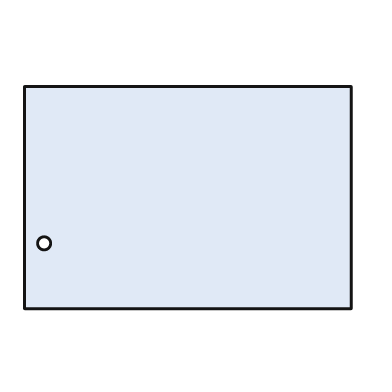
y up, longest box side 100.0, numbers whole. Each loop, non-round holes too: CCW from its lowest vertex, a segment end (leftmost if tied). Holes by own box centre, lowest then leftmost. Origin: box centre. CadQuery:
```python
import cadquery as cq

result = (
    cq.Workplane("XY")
    .moveTo(-50.0, -34.0)
    .lineTo(50.0, -34.0)
    .lineTo(50.0, 34.0)
    .lineTo(-50.0, 34.0)
    .close()
    .moveTo(-44.0, -14.0)
    .circle(2.0)
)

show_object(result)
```